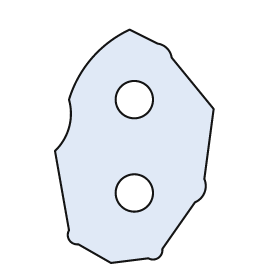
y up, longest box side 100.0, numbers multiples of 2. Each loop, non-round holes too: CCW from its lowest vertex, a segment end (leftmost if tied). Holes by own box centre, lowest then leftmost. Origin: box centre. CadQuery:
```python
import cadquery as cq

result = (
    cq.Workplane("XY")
    .moveTo(-10.0, -50.0)
    .lineTo(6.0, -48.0)
    .threePointArc((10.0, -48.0), (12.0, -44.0))
    .lineTo(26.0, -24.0)
    .threePointArc((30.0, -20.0), (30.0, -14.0))
    .lineTo(34.0, 16.0)
    .lineTo(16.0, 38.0)
    .threePointArc((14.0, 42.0), (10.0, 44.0))
    .lineTo(-2.0, 50.0)
    .threePointArc((-18.0, 38.0), (-28.0, 20.0))
    .threePointArc((-28.0, 8.0), (-34.0, -2.0))
    .lineTo(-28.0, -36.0)
    .threePointArc((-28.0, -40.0), (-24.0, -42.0))
    .close()
    .moveTo(0.0, -20.0)
    .circle(8.0)
    .moveTo(0.0, 20.0)
    .circle(8.0)
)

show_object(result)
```